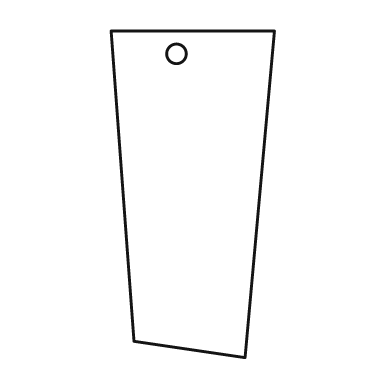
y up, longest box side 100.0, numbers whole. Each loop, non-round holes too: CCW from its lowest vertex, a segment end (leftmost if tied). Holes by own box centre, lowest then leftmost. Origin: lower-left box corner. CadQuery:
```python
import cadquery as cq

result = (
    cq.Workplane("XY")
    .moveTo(41.0, 0.0)
    .lineTo(50.0, 100.0)
    .lineTo(0.0, 100.0)
    .lineTo(7.0, 5.0)
    .close()
    .moveTo(20.0, 93.0)
    .circle(3.0)
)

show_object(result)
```